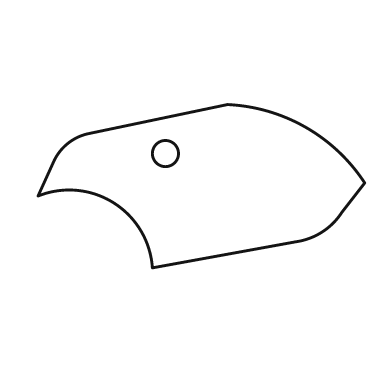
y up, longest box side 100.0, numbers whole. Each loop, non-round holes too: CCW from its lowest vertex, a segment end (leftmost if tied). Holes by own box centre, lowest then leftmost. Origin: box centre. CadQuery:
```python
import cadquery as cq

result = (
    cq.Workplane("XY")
    .moveTo(-15.0, -25.0)
    .lineTo(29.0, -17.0)
    .threePointArc((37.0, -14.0), (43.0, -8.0))
    .lineTo(50.0, 1.0)
    .threePointArc((32.0, 18.0), (8.0, 25.0))
    .lineTo(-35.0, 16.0)
    .threePointArc((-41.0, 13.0), (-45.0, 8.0))
    .lineTo(-50.0, -3.0)
    .threePointArc((-27.0, -5.0), (-15.0, -25.0))
    .close()
    .moveTo(-11.0, 10.0)
    .circle(4.0)
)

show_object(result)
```